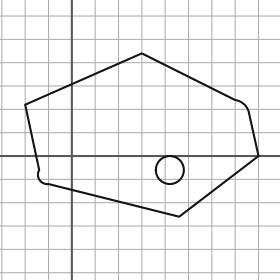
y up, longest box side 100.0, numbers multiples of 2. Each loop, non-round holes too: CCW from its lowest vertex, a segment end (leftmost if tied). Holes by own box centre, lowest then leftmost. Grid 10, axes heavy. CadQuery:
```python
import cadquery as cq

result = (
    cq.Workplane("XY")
    .moveTo(46.0, -26.0)
    .lineTo(80.0, 0.0)
    .lineTo(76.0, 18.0)
    .threePointArc((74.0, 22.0), (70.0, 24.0))
    .lineTo(30.0, 44.0)
    .lineTo(-20.0, 22.0)
    .lineTo(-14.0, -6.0)
    .threePointArc((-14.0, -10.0), (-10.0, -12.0))
    .close()
    .moveTo(42.0, -6.0)
    .circle(6.0)
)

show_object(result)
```